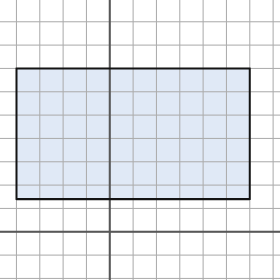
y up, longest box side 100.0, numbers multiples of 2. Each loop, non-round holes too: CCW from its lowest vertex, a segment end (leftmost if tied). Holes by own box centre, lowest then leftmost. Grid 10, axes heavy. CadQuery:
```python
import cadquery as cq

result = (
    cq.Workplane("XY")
    .moveTo(-40.0, 14.0)
    .lineTo(60.0, 14.0)
    .lineTo(60.0, 70.0)
    .lineTo(-40.0, 70.0)
    .close()
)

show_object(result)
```